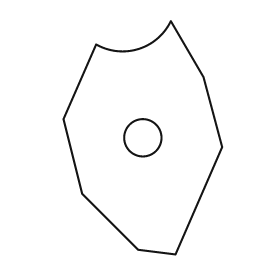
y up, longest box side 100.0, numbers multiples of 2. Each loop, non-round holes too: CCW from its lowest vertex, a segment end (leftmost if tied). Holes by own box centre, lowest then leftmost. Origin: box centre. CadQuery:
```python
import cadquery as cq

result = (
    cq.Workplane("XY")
    .moveTo(14.0, -50.0)
    .lineTo(34.0, -4.0)
    .lineTo(26.0, 26.0)
    .lineTo(12.0, 50.0)
    .threePointArc((-2.0, 38.0), (-20.0, 40.0))
    .lineTo(-34.0, 8.0)
    .lineTo(-26.0, -24.0)
    .lineTo(-2.0, -48.0)
    .close()
    .moveTo(0.0, 0.0)
    .circle(8.0)
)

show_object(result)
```